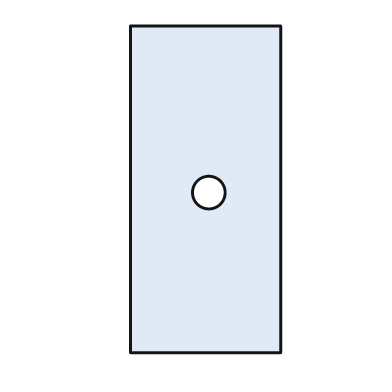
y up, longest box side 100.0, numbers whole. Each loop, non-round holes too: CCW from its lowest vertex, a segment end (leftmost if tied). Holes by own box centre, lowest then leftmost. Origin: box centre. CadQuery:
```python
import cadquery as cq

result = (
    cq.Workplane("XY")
    .moveTo(-23.0, -50.0)
    .lineTo(23.0, -50.0)
    .lineTo(23.0, 50.0)
    .lineTo(-23.0, 50.0)
    .close()
    .moveTo(1.0, -1.0)
    .circle(5.0)
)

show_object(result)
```